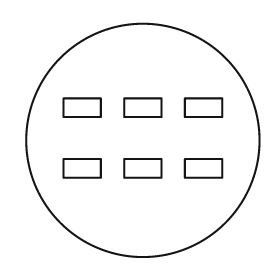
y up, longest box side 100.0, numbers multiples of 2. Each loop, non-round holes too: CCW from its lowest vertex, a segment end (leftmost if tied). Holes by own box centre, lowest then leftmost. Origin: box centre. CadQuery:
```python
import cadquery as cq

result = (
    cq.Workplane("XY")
    .moveTo(0.0, 0.0)
    .circle(50.0)
    .moveTo(-34.0, -16.0)
    .lineTo(-18.0, -16.0)
    .lineTo(-18.0, -8.0)
    .lineTo(-34.0, -8.0)
    .close()
    .moveTo(-8.0, -16.0)
    .lineTo(8.0, -16.0)
    .lineTo(8.0, -8.0)
    .lineTo(-8.0, -8.0)
    .close()
    .moveTo(18.0, -16.0)
    .lineTo(34.0, -16.0)
    .lineTo(34.0, -8.0)
    .lineTo(18.0, -8.0)
    .close()
    .moveTo(-34.0, 10.0)
    .lineTo(-18.0, 10.0)
    .lineTo(-18.0, 18.0)
    .lineTo(-34.0, 18.0)
    .close()
    .moveTo(-8.0, 10.0)
    .lineTo(8.0, 10.0)
    .lineTo(8.0, 18.0)
    .lineTo(-8.0, 18.0)
    .close()
    .moveTo(18.0, 10.0)
    .lineTo(34.0, 10.0)
    .lineTo(34.0, 18.0)
    .lineTo(18.0, 18.0)
    .close()
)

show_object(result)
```